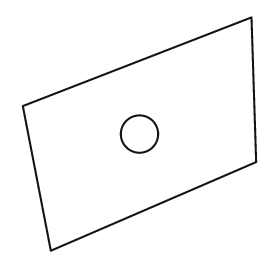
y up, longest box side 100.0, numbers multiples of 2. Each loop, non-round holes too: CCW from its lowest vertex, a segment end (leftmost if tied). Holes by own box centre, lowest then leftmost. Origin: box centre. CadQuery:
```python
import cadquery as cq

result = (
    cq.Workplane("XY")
    .moveTo(-38.0, -50.0)
    .lineTo(50.0, -12.0)
    .lineTo(48.0, 50.0)
    .lineTo(-50.0, 12.0)
    .close()
    .moveTo(0.0, 0.0)
    .circle(8.0)
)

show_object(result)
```